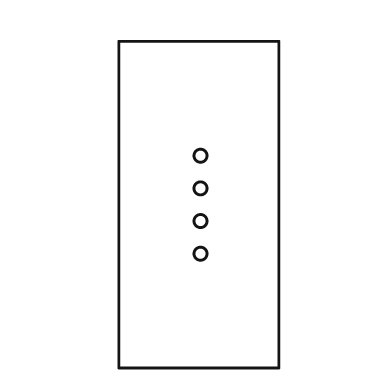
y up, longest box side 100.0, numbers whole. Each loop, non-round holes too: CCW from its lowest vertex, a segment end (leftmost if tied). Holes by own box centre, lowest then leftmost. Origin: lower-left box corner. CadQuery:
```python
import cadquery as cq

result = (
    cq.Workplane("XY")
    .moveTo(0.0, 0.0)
    .lineTo(49.0, 0.0)
    .lineTo(49.0, 100.0)
    .lineTo(0.0, 100.0)
    .close()
    .moveTo(25.0, 35.0)
    .circle(2.0)
    .moveTo(25.0, 45.0)
    .circle(2.0)
    .moveTo(25.0, 55.0)
    .circle(2.0)
    .moveTo(25.0, 65.0)
    .circle(2.0)
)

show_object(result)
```